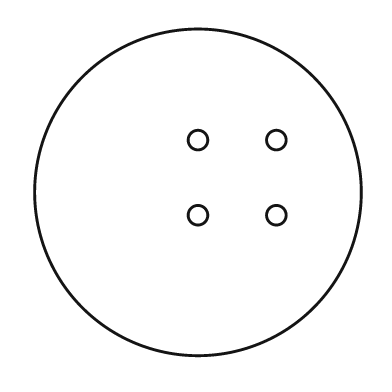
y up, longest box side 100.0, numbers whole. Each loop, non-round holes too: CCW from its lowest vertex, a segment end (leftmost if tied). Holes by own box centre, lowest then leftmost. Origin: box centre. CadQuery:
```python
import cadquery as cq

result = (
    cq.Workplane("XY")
    .moveTo(0.0, 0.0)
    .circle(50.0)
    .moveTo(0.0, -7.0)
    .circle(3.0)
    .moveTo(24.0, -7.0)
    .circle(3.0)
    .moveTo(0.0, 16.0)
    .circle(3.0)
    .moveTo(24.0, 16.0)
    .circle(3.0)
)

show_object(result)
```